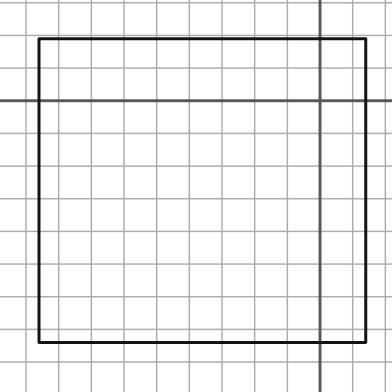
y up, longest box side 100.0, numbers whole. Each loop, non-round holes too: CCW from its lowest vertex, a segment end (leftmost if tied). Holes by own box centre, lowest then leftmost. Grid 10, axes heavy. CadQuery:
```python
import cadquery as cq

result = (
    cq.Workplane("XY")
    .moveTo(-86.0, -74.0)
    .lineTo(14.0, -74.0)
    .lineTo(14.0, 19.0)
    .lineTo(-86.0, 19.0)
    .close()
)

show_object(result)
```